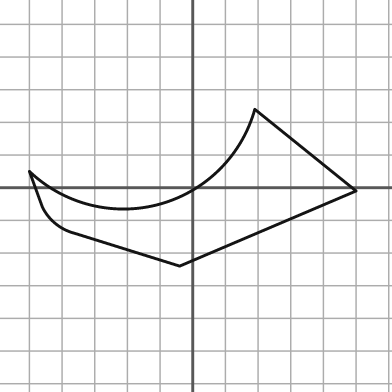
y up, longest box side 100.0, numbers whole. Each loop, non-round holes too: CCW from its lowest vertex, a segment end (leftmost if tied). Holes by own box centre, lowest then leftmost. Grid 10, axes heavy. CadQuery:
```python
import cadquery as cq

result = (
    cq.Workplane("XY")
    .moveTo(-4.0, -24.0)
    .lineTo(50.0, -1.0)
    .lineTo(19.0, 24.0)
    .threePointArc((-10.0, -5.0), (-50.0, 5.0))
    .lineTo(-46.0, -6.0)
    .threePointArc((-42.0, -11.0), (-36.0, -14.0))
    .close()
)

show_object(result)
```